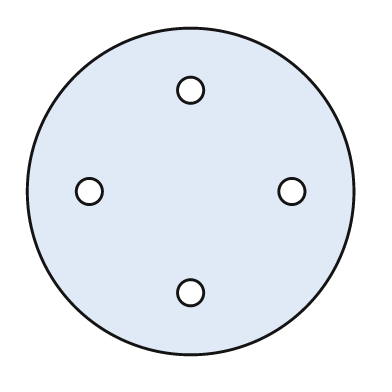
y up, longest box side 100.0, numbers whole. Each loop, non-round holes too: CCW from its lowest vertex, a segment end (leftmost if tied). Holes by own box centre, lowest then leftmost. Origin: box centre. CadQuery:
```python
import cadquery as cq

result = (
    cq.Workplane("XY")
    .moveTo(0.0, 0.0)
    .circle(50.0)
    .moveTo(0.0, -31.0)
    .circle(4.0)
    .moveTo(-31.0, 0.0)
    .circle(4.0)
    .moveTo(31.0, 0.0)
    .circle(4.0)
    .moveTo(0.0, 31.0)
    .circle(4.0)
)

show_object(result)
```